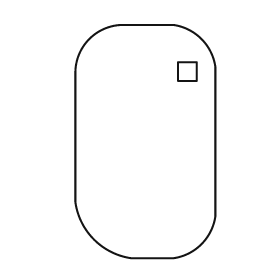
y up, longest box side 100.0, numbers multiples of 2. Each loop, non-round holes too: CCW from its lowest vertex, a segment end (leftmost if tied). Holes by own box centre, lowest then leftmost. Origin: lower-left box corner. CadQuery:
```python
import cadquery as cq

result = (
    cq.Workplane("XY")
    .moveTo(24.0, 0.0)
    .lineTo(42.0, 0.0)
    .threePointArc((54.0, 6.0), (60.0, 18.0))
    .lineTo(60.0, 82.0)
    .threePointArc((54.0, 94.0), (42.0, 100.0))
    .lineTo(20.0, 100.0)
    .threePointArc((6.0, 94.0), (0.0, 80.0))
    .lineTo(0.0, 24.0)
    .threePointArc((8.0, 8.0), (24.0, 0.0))
    .close()
    .moveTo(44.0, 76.0)
    .lineTo(52.0, 76.0)
    .lineTo(52.0, 84.0)
    .lineTo(44.0, 84.0)
    .close()
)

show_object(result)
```